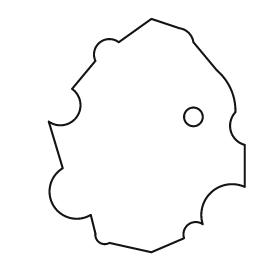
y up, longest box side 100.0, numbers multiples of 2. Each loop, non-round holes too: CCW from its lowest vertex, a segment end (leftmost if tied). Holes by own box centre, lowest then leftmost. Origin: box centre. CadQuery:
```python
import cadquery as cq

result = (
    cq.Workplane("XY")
    .moveTo(2.0, -50.0)
    .lineTo(16.0, -44.0)
    .threePointArc((18.0, -38.0), (24.0, -38.0))
    .threePointArc((28.0, -24.0), (42.0, -22.0))
    .lineTo(42.0, -4.0)
    .threePointArc((36.0, 2.0), (38.0, 10.0))
    .threePointArc((36.0, 20.0), (30.0, 28.0))
    .lineTo(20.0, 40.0)
    .threePointArc((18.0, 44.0), (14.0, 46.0))
    .lineTo(2.0, 50.0)
    .lineTo(-12.0, 40.0)
    .threePointArc((-20.0, 40.0), (-22.0, 32.0))
    .lineTo(-32.0, 20.0)
    .threePointArc((-30.0, 8.0), (-42.0, 6.0))
    .lineTo(-36.0, -14.0)
    .threePointArc((-40.0, -30.0), (-24.0, -34.0))
    .lineTo(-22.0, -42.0)
    .threePointArc((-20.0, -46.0), (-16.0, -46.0))
    .close()
    .moveTo(20.0, 8.0)
    .circle(4.0)
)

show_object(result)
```